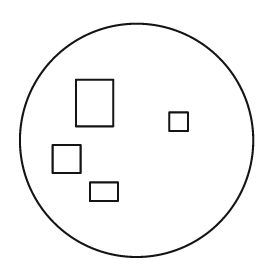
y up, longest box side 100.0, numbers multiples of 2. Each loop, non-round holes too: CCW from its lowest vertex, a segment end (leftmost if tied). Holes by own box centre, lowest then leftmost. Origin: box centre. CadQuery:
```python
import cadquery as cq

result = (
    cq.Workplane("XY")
    .moveTo(0.0, 0.0)
    .circle(50.0)
    .moveTo(-20.0, -26.0)
    .lineTo(-8.0, -26.0)
    .lineTo(-8.0, -18.0)
    .lineTo(-20.0, -18.0)
    .close()
    .moveTo(-36.0, -14.0)
    .lineTo(-24.0, -14.0)
    .lineTo(-24.0, -2.0)
    .lineTo(-36.0, -2.0)
    .close()
    .moveTo(14.0, 4.0)
    .lineTo(22.0, 4.0)
    .lineTo(22.0, 12.0)
    .lineTo(14.0, 12.0)
    .close()
    .moveTo(-26.0, 6.0)
    .lineTo(-10.0, 6.0)
    .lineTo(-10.0, 26.0)
    .lineTo(-26.0, 26.0)
    .close()
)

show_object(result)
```